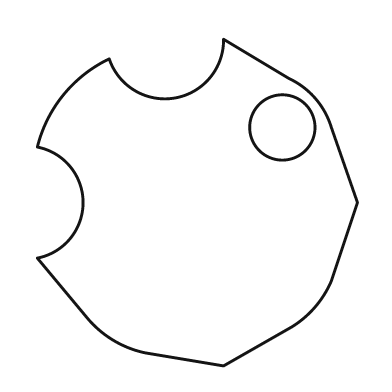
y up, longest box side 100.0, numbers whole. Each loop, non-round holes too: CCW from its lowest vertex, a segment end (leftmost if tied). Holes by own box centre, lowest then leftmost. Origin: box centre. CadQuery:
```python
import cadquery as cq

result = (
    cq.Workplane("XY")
    .moveTo(8.0, -50.0)
    .lineTo(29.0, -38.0)
    .threePointArc((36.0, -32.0), (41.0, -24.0))
    .lineTo(49.0, 0.0)
    .lineTo(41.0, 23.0)
    .threePointArc((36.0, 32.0), (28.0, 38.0))
    .lineTo(8.0, 50.0)
    .threePointArc((-7.0, 32.0), (-27.0, 44.0))
    .threePointArc((-41.0, 33.0), (-49.0, 17.0))
    .threePointArc((-35.0, 0.0), (-49.0, -17.0))
    .lineTo(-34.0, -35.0)
    .threePointArc((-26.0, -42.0), (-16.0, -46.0))
    .close()
    .moveTo(26.0, 23.0)
    .circle(10.0)
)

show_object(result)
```